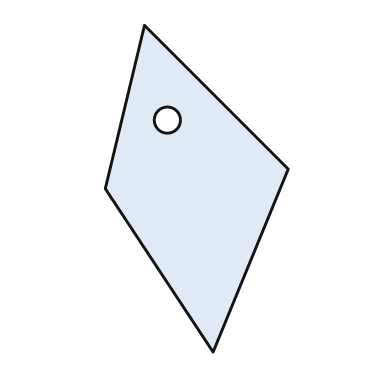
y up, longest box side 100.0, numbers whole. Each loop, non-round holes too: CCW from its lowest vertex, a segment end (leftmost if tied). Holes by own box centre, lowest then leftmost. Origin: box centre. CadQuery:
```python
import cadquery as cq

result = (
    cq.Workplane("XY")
    .moveTo(5.0, -50.0)
    .lineTo(28.0, 6.0)
    .lineTo(-16.0, 50.0)
    .lineTo(-28.0, 0.0)
    .close()
    .moveTo(-9.0, 21.0)
    .circle(4.0)
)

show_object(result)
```